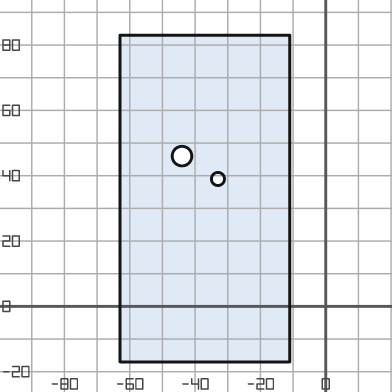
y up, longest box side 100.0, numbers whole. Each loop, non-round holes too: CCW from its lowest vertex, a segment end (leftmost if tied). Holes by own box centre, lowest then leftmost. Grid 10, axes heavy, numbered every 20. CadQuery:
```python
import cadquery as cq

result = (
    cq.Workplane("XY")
    .moveTo(-63.0, -17.0)
    .lineTo(-11.0, -17.0)
    .lineTo(-11.0, 83.0)
    .lineTo(-63.0, 83.0)
    .close()
    .moveTo(-33.0, 39.0)
    .circle(2.0)
    .moveTo(-44.0, 46.0)
    .circle(3.0)
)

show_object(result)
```